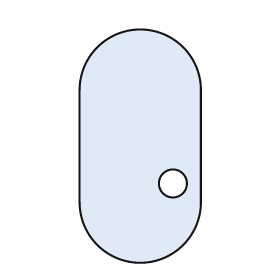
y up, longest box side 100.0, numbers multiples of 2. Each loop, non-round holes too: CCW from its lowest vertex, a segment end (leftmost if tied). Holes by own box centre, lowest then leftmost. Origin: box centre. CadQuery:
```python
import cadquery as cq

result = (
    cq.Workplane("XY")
    .moveTo(-26.0, -24.0)
    .threePointArc((0.0, -50.0), (26.0, -24.0))
    .lineTo(26.0, 24.0)
    .threePointArc((0.0, 50.0), (-26.0, 24.0))
    .close()
    .moveTo(14.0, -16.0)
    .circle(6.0)
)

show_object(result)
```